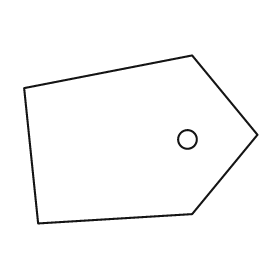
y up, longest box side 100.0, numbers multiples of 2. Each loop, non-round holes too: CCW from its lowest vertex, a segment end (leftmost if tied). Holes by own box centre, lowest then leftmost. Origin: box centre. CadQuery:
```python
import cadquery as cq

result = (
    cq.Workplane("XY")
    .moveTo(-44.0, -36.0)
    .lineTo(22.0, -32.0)
    .lineTo(50.0, 2.0)
    .lineTo(22.0, 36.0)
    .lineTo(-50.0, 22.0)
    .close()
    .moveTo(20.0, 0.0)
    .circle(4.0)
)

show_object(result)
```